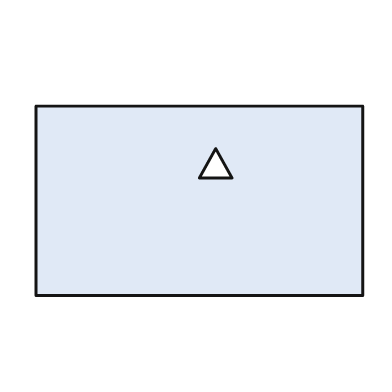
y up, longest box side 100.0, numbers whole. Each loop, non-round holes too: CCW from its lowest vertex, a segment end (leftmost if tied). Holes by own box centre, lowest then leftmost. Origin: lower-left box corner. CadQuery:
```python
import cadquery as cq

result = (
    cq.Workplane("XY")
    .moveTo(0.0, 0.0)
    .lineTo(100.0, 0.0)
    .lineTo(100.0, 58.0)
    .lineTo(0.0, 58.0)
    .close()
    .moveTo(50.0, 36.0)
    .lineTo(60.0, 36.0)
    .lineTo(55.0, 45.0)
    .close()
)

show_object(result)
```